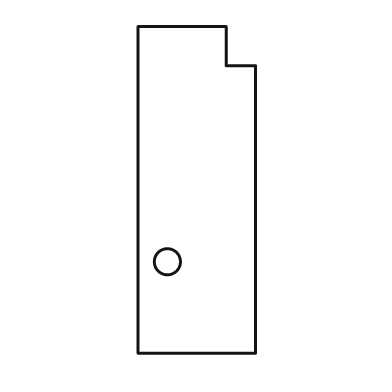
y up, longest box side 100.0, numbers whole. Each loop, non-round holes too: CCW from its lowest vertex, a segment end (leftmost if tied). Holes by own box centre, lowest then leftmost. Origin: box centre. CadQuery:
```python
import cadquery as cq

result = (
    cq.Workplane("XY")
    .moveTo(-18.0, -50.0)
    .lineTo(18.0, -50.0)
    .lineTo(18.0, 38.0)
    .lineTo(9.0, 38.0)
    .lineTo(9.0, 50.0)
    .lineTo(-18.0, 50.0)
    .close()
    .moveTo(-9.0, -22.0)
    .circle(4.0)
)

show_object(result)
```